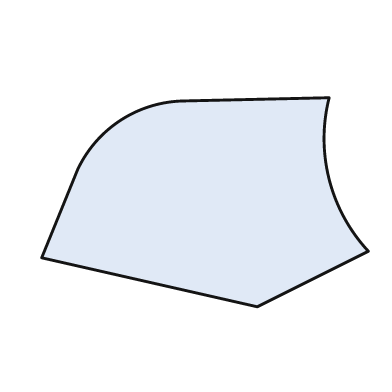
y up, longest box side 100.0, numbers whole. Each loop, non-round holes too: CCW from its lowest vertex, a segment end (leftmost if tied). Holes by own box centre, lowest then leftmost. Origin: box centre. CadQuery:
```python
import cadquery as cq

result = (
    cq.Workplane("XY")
    .moveTo(16.0, -32.0)
    .lineTo(50.0, -15.0)
    .threePointArc((38.0, 7.0), (38.0, 32.0))
    .lineTo(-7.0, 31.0)
    .threePointArc((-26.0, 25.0), (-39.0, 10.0))
    .lineTo(-50.0, -17.0)
    .close()
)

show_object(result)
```